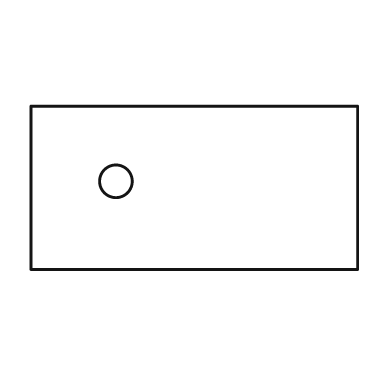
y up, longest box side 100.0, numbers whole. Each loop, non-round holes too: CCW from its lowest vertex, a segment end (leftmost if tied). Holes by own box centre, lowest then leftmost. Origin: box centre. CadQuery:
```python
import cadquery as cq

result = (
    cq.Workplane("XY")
    .moveTo(-50.0, -25.0)
    .lineTo(50.0, -25.0)
    .lineTo(50.0, 25.0)
    .lineTo(-50.0, 25.0)
    .close()
    .moveTo(-24.0, 2.0)
    .circle(5.0)
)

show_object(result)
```